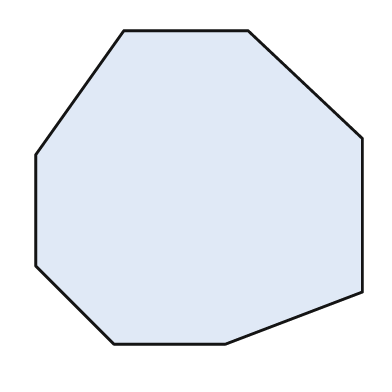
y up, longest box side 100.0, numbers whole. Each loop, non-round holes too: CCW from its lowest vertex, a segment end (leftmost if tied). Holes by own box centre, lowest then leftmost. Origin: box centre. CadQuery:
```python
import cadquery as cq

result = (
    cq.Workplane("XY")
    .moveTo(-26.0, -48.0)
    .lineTo(8.0, -48.0)
    .lineTo(50.0, -32.0)
    .lineTo(50.0, 15.0)
    .lineTo(15.0, 48.0)
    .lineTo(-23.0, 48.0)
    .lineTo(-50.0, 10.0)
    .lineTo(-50.0, -24.0)
    .close()
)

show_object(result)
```